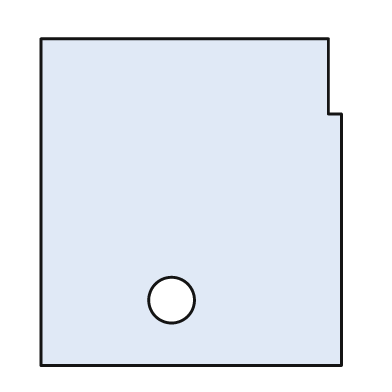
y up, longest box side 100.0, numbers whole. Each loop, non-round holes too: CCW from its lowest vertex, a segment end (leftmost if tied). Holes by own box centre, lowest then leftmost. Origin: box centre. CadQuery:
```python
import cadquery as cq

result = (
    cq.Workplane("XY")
    .moveTo(-46.0, -50.0)
    .lineTo(46.0, -50.0)
    .lineTo(46.0, 27.0)
    .lineTo(42.0, 27.0)
    .lineTo(42.0, 50.0)
    .lineTo(-46.0, 50.0)
    .close()
    .moveTo(-6.0, -30.0)
    .circle(7.0)
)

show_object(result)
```